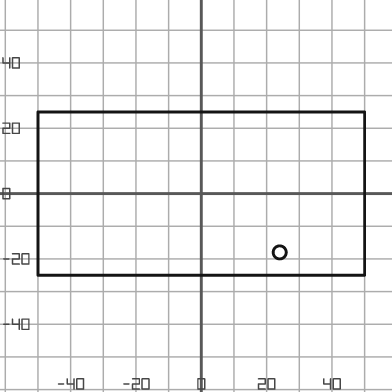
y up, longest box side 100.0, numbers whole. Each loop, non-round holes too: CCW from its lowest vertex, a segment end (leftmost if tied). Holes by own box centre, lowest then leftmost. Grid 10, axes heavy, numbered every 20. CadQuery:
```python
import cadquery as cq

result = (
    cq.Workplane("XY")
    .moveTo(-50.0, -25.0)
    .lineTo(50.0, -25.0)
    .lineTo(50.0, 25.0)
    .lineTo(-50.0, 25.0)
    .close()
    .moveTo(24.0, -18.0)
    .circle(2.0)
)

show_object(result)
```